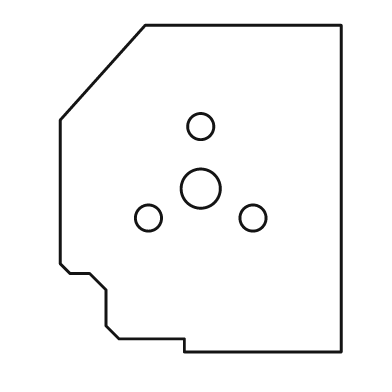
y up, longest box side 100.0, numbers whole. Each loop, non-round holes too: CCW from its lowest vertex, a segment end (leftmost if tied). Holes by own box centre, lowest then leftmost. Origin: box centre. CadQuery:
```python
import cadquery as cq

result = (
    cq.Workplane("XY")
    .moveTo(-5.0, -50.0)
    .lineTo(43.0, -50.0)
    .lineTo(43.0, 50.0)
    .lineTo(-17.0, 50.0)
    .lineTo(-43.0, 21.0)
    .lineTo(-43.0, -23.0)
    .lineTo(-40.0, -26.0)
    .lineTo(-34.0, -26.0)
    .lineTo(-29.0, -31.0)
    .lineTo(-29.0, -42.0)
    .lineTo(-25.0, -46.0)
    .lineTo(-5.0, -46.0)
    .close()
    .moveTo(-16.0, -9.0)
    .circle(4.0)
    .moveTo(16.0, -9.0)
    .circle(4.0)
    .moveTo(0.0, 0.0)
    .circle(6.0)
    .moveTo(0.0, 19.0)
    .circle(4.0)
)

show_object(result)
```